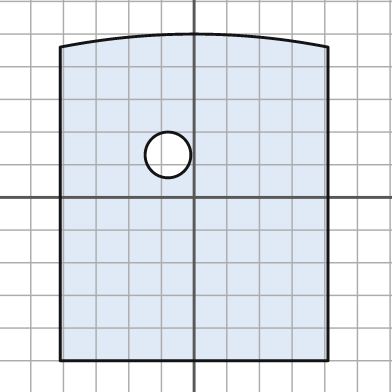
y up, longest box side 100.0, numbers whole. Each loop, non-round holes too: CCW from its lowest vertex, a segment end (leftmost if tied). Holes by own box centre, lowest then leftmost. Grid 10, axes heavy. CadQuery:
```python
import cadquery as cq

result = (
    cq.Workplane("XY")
    .moveTo(-41.0, -50.0)
    .lineTo(41.0, -50.0)
    .lineTo(41.0, 46.0)
    .threePointArc((0.0, 50.0), (-41.0, 46.0))
    .close()
    .moveTo(-8.0, 13.0)
    .circle(7.0)
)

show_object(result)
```